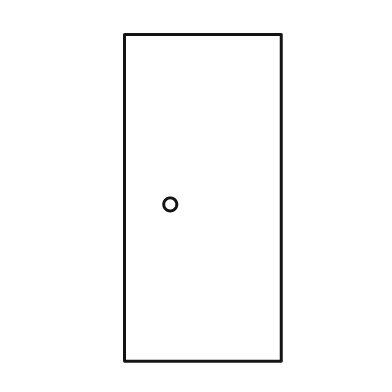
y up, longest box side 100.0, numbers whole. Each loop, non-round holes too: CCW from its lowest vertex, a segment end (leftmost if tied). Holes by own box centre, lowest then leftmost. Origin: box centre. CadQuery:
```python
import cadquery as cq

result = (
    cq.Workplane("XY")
    .moveTo(-24.0, -50.0)
    .lineTo(24.0, -50.0)
    .lineTo(24.0, 50.0)
    .lineTo(-24.0, 50.0)
    .close()
    .moveTo(-10.0, -2.0)
    .circle(2.0)
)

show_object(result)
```